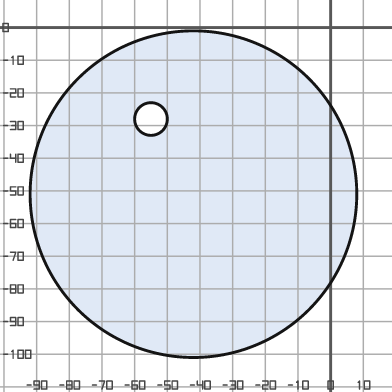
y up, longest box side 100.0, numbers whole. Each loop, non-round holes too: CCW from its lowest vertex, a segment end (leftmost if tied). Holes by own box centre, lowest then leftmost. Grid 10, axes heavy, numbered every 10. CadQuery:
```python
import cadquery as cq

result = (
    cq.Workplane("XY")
    .moveTo(-42.0, -51.0)
    .circle(50.0)
    .moveTo(-55.0, -28.0)
    .circle(5.0)
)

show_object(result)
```